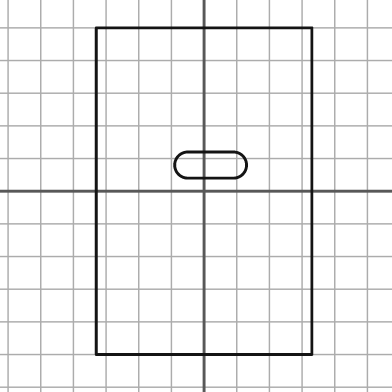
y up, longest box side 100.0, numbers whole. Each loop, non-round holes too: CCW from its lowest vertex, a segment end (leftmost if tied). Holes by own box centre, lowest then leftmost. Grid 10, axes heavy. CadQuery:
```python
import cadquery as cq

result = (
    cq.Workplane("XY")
    .moveTo(-33.0, -50.0)
    .lineTo(33.0, -50.0)
    .lineTo(33.0, 50.0)
    .lineTo(-33.0, 50.0)
    .close()
    .moveTo(-5.0, 4.0)
    .lineTo(9.0, 4.0)
    .threePointArc((13.0, 8.0), (9.0, 12.0))
    .lineTo(-5.0, 12.0)
    .threePointArc((-9.0, 8.0), (-5.0, 4.0))
    .close()
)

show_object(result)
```